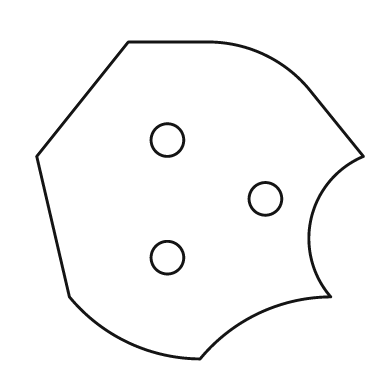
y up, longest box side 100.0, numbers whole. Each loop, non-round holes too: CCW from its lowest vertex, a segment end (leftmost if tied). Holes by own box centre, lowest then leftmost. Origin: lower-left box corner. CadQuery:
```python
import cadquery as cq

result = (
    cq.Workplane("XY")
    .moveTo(50.0, 0.0)
    .threePointArc((68.0, 14.0), (90.0, 19.0))
    .threePointArc((84.0, 43.0), (100.0, 62.0))
    .lineTo(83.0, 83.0)
    .threePointArc((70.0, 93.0), (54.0, 97.0))
    .lineTo(28.0, 97.0)
    .lineTo(0.0, 62.0)
    .lineTo(10.0, 19.0)
    .threePointArc((28.0, 5.0), (50.0, 0.0))
    .close()
    .moveTo(40.0, 31.0)
    .circle(5.0)
    .moveTo(70.0, 49.0)
    .circle(5.0)
    .moveTo(40.0, 67.0)
    .circle(5.0)
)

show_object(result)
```